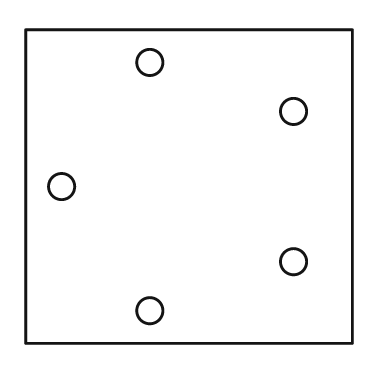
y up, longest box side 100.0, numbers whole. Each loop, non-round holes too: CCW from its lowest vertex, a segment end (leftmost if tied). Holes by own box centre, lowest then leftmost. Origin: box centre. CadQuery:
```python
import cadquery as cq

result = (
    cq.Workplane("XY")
    .moveTo(-50.0, -48.0)
    .lineTo(50.0, -48.0)
    .lineTo(50.0, 48.0)
    .lineTo(-50.0, 48.0)
    .close()
    .moveTo(-12.0, -38.0)
    .circle(4.0)
    .moveTo(32.0, -23.0)
    .circle(4.0)
    .moveTo(-39.0, 0.0)
    .circle(4.0)
    .moveTo(32.0, 23.0)
    .circle(4.0)
    .moveTo(-12.0, 38.0)
    .circle(4.0)
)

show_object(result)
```